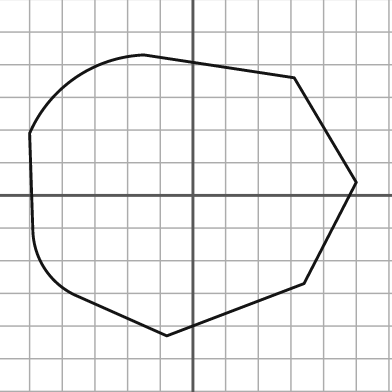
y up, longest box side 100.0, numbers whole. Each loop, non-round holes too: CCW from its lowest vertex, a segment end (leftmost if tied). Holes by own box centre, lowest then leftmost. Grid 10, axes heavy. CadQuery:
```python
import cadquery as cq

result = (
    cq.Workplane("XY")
    .moveTo(-8.0, -43.0)
    .lineTo(34.0, -27.0)
    .lineTo(50.0, 4.0)
    .lineTo(31.0, 36.0)
    .lineTo(-15.0, 43.0)
    .threePointArc((-36.0, 36.0), (-50.0, 19.0))
    .lineTo(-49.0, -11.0)
    .threePointArc((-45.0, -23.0), (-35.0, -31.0))
    .close()
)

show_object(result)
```